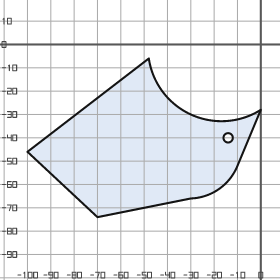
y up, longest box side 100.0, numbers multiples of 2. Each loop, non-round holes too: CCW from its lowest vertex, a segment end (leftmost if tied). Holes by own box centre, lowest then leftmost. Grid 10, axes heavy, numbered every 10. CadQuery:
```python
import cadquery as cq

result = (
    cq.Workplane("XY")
    .moveTo(-70.0, -74.0)
    .lineTo(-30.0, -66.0)
    .threePointArc((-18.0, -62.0), (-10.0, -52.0))
    .lineTo(0.0, -28.0)
    .threePointArc((-30.0, -30.0), (-48.0, -6.0))
    .lineTo(-100.0, -46.0)
    .close()
    .moveTo(-14.0, -40.0)
    .circle(2.0)
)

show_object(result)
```